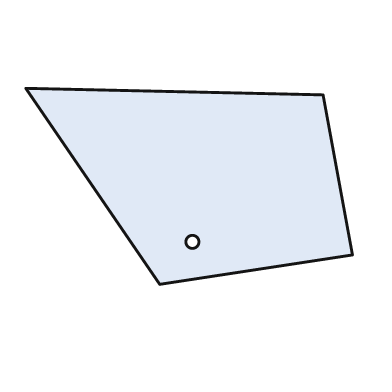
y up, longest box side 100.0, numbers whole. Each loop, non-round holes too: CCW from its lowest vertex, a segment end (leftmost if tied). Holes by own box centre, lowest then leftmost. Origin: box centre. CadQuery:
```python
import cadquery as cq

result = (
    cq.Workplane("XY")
    .moveTo(-9.0, -30.0)
    .lineTo(50.0, -21.0)
    .lineTo(41.0, 28.0)
    .lineTo(-50.0, 30.0)
    .close()
    .moveTo(1.0, -17.0)
    .circle(2.0)
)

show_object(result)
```